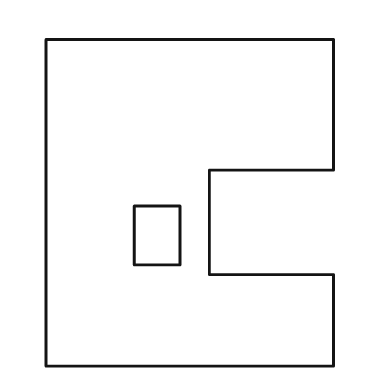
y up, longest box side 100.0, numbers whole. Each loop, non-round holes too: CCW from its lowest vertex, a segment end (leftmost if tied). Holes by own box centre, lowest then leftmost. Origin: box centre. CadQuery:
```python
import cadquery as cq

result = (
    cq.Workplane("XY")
    .moveTo(-44.0, -50.0)
    .lineTo(44.0, -50.0)
    .lineTo(44.0, -22.0)
    .lineTo(6.0, -22.0)
    .lineTo(6.0, 10.0)
    .lineTo(44.0, 10.0)
    .lineTo(44.0, 50.0)
    .lineTo(-44.0, 50.0)
    .close()
    .moveTo(-17.0, -19.0)
    .lineTo(-3.0, -19.0)
    .lineTo(-3.0, -1.0)
    .lineTo(-17.0, -1.0)
    .close()
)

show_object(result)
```